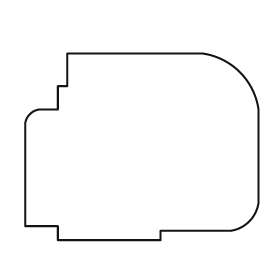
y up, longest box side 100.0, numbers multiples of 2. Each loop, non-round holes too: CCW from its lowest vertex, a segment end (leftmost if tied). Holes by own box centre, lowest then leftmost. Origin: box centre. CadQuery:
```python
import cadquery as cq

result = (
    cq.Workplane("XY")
    .moveTo(-36.0, -40.0)
    .lineTo(8.0, -40.0)
    .lineTo(8.0, -36.0)
    .lineTo(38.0, -36.0)
    .threePointArc((46.0, -32.0), (50.0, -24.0))
    .lineTo(50.0, 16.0)
    .threePointArc((42.0, 32.0), (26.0, 40.0))
    .lineTo(-32.0, 40.0)
    .lineTo(-32.0, 26.0)
    .lineTo(-36.0, 26.0)
    .lineTo(-36.0, 16.0)
    .lineTo(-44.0, 16.0)
    .threePointArc((-48.0, 14.0), (-50.0, 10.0))
    .lineTo(-50.0, -34.0)
    .lineTo(-36.0, -34.0)
    .close()
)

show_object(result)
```